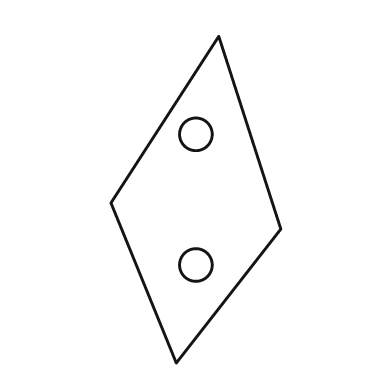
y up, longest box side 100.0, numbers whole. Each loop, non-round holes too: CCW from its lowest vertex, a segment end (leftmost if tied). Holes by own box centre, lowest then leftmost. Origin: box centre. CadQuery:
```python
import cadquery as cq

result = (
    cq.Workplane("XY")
    .moveTo(-6.0, -50.0)
    .lineTo(26.0, -9.0)
    .lineTo(7.0, 50.0)
    .lineTo(-26.0, -1.0)
    .close()
    .moveTo(0.0, -20.0)
    .circle(5.0)
    .moveTo(0.0, 20.0)
    .circle(5.0)
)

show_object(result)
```